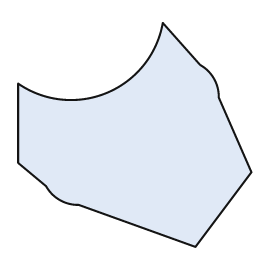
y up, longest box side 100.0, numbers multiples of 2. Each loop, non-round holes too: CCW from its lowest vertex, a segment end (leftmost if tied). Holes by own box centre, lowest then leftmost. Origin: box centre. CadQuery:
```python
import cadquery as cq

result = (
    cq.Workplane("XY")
    .moveTo(26.0, -48.0)
    .lineTo(50.0, -16.0)
    .lineTo(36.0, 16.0)
    .threePointArc((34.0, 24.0), (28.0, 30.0))
    .lineTo(12.0, 48.0)
    .threePointArc((-12.0, 18.0), (-50.0, 22.0))
    .lineTo(-50.0, -12.0)
    .lineTo(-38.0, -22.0)
    .threePointArc((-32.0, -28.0), (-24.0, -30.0))
    .close()
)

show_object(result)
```